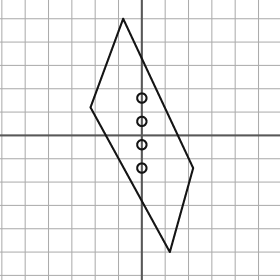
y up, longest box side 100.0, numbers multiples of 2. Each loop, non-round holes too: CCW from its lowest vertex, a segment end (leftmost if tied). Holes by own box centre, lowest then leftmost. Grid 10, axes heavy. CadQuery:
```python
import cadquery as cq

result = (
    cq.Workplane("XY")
    .moveTo(12.0, -50.0)
    .lineTo(22.0, -14.0)
    .lineTo(-8.0, 50.0)
    .lineTo(-22.0, 12.0)
    .close()
    .moveTo(0.0, -14.0)
    .circle(2.0)
    .moveTo(0.0, -4.0)
    .circle(2.0)
    .moveTo(0.0, 6.0)
    .circle(2.0)
    .moveTo(0.0, 16.0)
    .circle(2.0)
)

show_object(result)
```